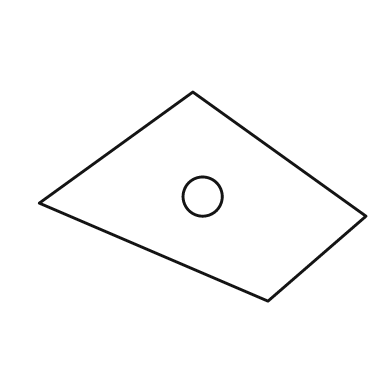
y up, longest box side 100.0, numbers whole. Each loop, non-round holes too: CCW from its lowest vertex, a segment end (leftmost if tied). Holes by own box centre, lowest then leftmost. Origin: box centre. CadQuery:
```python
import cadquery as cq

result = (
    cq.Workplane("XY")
    .moveTo(20.0, -32.0)
    .lineTo(50.0, -6.0)
    .lineTo(-3.0, 32.0)
    .lineTo(-50.0, -2.0)
    .close()
    .moveTo(0.0, 0.0)
    .circle(6.0)
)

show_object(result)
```